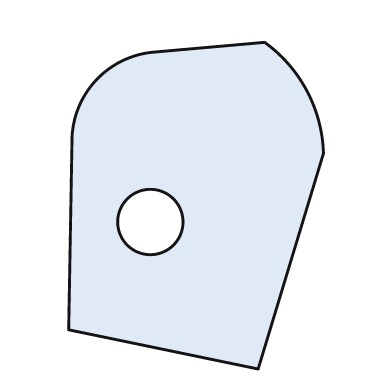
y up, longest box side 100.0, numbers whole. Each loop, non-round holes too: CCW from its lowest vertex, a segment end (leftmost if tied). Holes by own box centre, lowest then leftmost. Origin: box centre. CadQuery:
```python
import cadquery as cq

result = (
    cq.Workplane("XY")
    .moveTo(19.0, -50.0)
    .lineTo(39.0, 16.0)
    .threePointArc((34.0, 35.0), (21.0, 50.0))
    .lineTo(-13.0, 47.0)
    .threePointArc((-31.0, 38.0), (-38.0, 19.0))
    .lineTo(-39.0, -38.0)
    .close()
    .moveTo(-14.0, -5.0)
    .circle(10.0)
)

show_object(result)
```